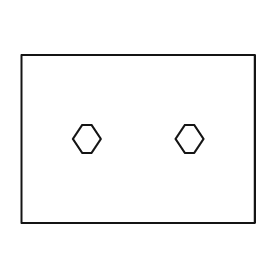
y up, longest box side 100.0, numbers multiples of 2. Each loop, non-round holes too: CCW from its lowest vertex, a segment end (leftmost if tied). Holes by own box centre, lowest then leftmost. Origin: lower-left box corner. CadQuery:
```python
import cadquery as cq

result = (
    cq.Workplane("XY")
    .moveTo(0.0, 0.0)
    .lineTo(100.0, 0.0)
    .lineTo(100.0, 72.0)
    .lineTo(0.0, 72.0)
    .close()
    .moveTo(26.0, 30.0)
    .lineTo(30.0, 30.0)
    .lineTo(34.0, 36.0)
    .lineTo(30.0, 42.0)
    .lineTo(26.0, 42.0)
    .lineTo(22.0, 36.0)
    .close()
    .moveTo(70.0, 30.0)
    .lineTo(74.0, 30.0)
    .lineTo(78.0, 36.0)
    .lineTo(74.0, 42.0)
    .lineTo(70.0, 42.0)
    .lineTo(66.0, 36.0)
    .close()
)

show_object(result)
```